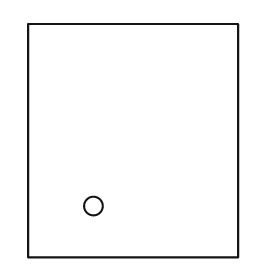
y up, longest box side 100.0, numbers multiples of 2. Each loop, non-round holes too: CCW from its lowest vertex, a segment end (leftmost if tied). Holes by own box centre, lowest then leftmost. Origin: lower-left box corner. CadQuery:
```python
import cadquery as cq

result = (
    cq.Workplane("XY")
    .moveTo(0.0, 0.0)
    .lineTo(90.0, 0.0)
    .lineTo(90.0, 100.0)
    .lineTo(0.0, 100.0)
    .close()
    .moveTo(28.0, 22.0)
    .circle(4.0)
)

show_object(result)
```